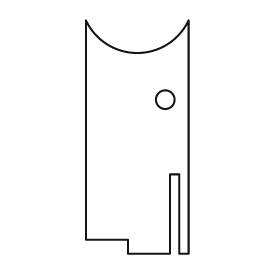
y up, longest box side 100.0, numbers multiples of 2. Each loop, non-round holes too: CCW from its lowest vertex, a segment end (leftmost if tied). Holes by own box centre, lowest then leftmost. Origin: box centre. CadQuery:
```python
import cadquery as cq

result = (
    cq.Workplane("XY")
    .moveTo(-4.0, -50.0)
    .lineTo(14.0, -50.0)
    .lineTo(14.0, -16.0)
    .lineTo(18.0, -16.0)
    .lineTo(18.0, -50.0)
    .lineTo(22.0, -50.0)
    .lineTo(22.0, 50.0)
    .threePointArc((0.0, 36.0), (-22.0, 50.0))
    .lineTo(-22.0, -44.0)
    .lineTo(-4.0, -44.0)
    .close()
    .moveTo(12.0, 16.0)
    .circle(4.0)
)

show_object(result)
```